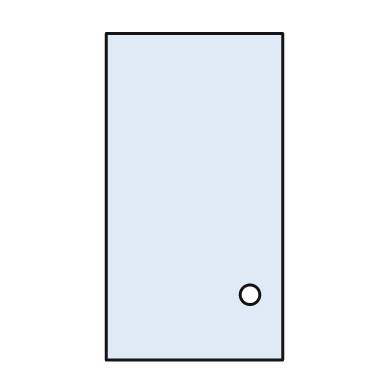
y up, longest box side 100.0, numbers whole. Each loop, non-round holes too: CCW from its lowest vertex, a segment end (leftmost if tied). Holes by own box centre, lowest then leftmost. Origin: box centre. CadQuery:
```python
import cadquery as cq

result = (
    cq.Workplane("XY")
    .moveTo(-27.0, -50.0)
    .lineTo(27.0, -50.0)
    .lineTo(27.0, 50.0)
    .lineTo(-27.0, 50.0)
    .close()
    .moveTo(17.0, -30.0)
    .circle(3.0)
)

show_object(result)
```